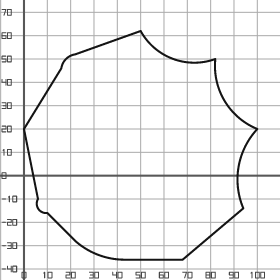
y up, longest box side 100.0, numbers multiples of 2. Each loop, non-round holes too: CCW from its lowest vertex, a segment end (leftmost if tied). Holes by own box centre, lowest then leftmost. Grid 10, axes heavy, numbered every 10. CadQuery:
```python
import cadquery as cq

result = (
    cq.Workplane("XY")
    .moveTo(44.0, -36.0)
    .lineTo(68.0, -36.0)
    .lineTo(94.0, -14.0)
    .threePointArc((92.0, 4.0), (100.0, 20.0))
    .threePointArc((86.0, 32.0), (82.0, 50.0))
    .threePointArc((64.0, 50.0), (50.0, 62.0))
    .lineTo(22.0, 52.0)
    .threePointArc((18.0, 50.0), (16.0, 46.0))
    .lineTo(0.0, 20.0)
    .lineTo(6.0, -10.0)
    .threePointArc((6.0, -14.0), (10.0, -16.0))
    .lineTo(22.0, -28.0)
    .threePointArc((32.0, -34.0), (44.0, -36.0))
    .close()
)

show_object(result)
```